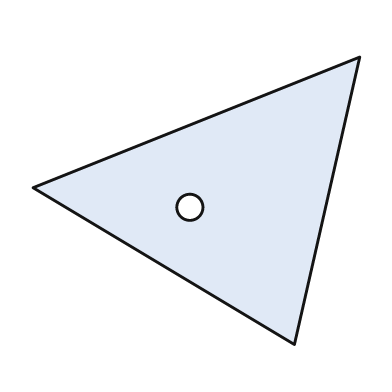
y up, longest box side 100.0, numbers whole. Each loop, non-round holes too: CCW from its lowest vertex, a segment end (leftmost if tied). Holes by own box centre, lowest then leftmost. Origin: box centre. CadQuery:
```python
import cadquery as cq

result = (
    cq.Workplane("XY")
    .moveTo(30.0, -44.0)
    .lineTo(50.0, 44.0)
    .lineTo(-50.0, 4.0)
    .close()
    .moveTo(-2.0, -2.0)
    .circle(4.0)
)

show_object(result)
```